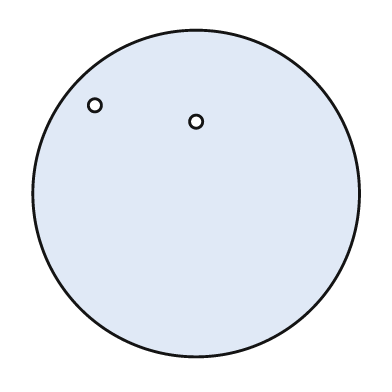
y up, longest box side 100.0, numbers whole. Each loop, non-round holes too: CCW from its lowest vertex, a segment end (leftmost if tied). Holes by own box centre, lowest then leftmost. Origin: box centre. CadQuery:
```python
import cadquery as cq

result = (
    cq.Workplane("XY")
    .moveTo(0.0, 0.0)
    .circle(50.0)
    .moveTo(0.0, 22.0)
    .circle(2.0)
    .moveTo(-31.0, 27.0)
    .circle(2.0)
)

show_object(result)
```